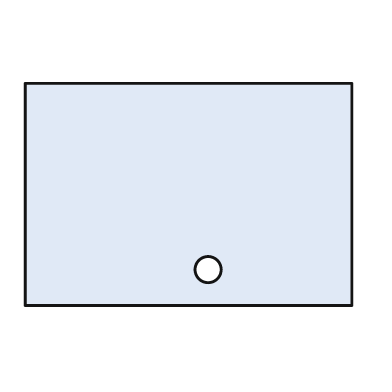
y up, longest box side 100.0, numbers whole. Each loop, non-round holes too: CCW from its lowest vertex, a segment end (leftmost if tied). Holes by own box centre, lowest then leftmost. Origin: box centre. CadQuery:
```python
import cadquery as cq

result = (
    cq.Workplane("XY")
    .moveTo(-50.0, -34.0)
    .lineTo(50.0, -34.0)
    .lineTo(50.0, 34.0)
    .lineTo(-50.0, 34.0)
    .close()
    .moveTo(6.0, -23.0)
    .circle(4.0)
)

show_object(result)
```